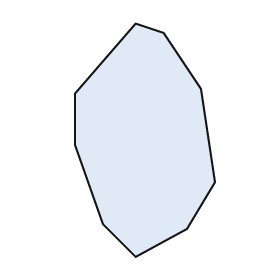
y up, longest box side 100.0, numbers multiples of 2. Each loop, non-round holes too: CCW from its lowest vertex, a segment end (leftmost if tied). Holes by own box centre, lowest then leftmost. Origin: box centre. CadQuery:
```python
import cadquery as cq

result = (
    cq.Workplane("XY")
    .moveTo(-4.0, -50.0)
    .lineTo(18.0, -38.0)
    .lineTo(30.0, -18.0)
    .lineTo(24.0, 22.0)
    .lineTo(8.0, 46.0)
    .lineTo(-4.0, 50.0)
    .lineTo(-30.0, 20.0)
    .lineTo(-30.0, -2.0)
    .lineTo(-18.0, -36.0)
    .close()
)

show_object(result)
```